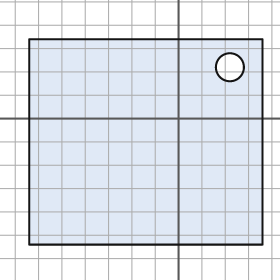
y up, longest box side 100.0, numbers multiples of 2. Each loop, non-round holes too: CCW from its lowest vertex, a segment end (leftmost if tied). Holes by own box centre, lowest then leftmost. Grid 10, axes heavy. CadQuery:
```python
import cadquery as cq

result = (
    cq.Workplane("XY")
    .moveTo(-64.0, -54.0)
    .lineTo(36.0, -54.0)
    .lineTo(36.0, 34.0)
    .lineTo(-64.0, 34.0)
    .close()
    .moveTo(22.0, 22.0)
    .circle(6.0)
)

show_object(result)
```